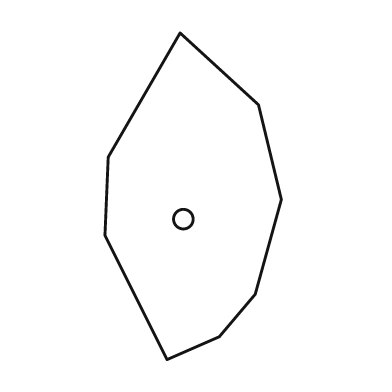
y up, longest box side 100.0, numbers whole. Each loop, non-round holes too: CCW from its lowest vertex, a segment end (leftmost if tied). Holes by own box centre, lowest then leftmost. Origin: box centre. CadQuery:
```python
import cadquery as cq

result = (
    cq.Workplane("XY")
    .moveTo(-8.0, -50.0)
    .lineTo(8.0, -43.0)
    .lineTo(19.0, -30.0)
    .lineTo(27.0, -1.0)
    .lineTo(20.0, 28.0)
    .lineTo(-4.0, 50.0)
    .lineTo(-26.0, 12.0)
    .lineTo(-27.0, -12.0)
    .close()
    .moveTo(-3.0, -7.0)
    .circle(3.0)
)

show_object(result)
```